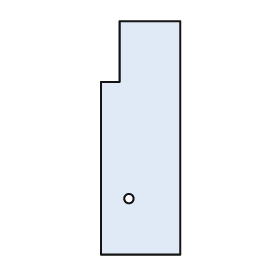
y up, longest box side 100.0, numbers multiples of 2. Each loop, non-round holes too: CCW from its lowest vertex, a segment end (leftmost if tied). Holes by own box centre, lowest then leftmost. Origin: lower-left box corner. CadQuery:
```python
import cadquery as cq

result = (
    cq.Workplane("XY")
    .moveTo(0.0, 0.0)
    .lineTo(34.0, 0.0)
    .lineTo(34.0, 100.0)
    .lineTo(8.0, 100.0)
    .lineTo(8.0, 74.0)
    .lineTo(0.0, 74.0)
    .close()
    .moveTo(12.0, 24.0)
    .circle(2.0)
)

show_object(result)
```